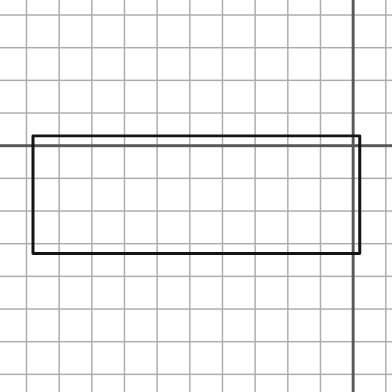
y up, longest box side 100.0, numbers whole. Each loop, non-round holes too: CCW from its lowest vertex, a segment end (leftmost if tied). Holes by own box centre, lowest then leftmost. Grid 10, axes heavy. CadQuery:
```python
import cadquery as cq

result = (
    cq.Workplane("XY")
    .moveTo(-98.0, -33.0)
    .lineTo(2.0, -33.0)
    .lineTo(2.0, 3.0)
    .lineTo(-98.0, 3.0)
    .close()
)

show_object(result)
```